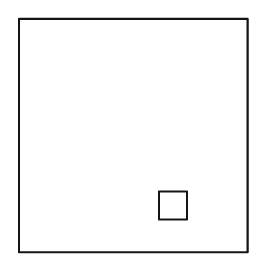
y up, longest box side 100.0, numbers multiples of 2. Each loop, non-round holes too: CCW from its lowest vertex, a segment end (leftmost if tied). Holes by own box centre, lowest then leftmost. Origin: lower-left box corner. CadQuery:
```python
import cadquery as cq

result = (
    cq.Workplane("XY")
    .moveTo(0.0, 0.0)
    .lineTo(98.0, 0.0)
    .lineTo(98.0, 100.0)
    .lineTo(0.0, 100.0)
    .close()
    .moveTo(60.0, 14.0)
    .lineTo(72.0, 14.0)
    .lineTo(72.0, 26.0)
    .lineTo(60.0, 26.0)
    .close()
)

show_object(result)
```